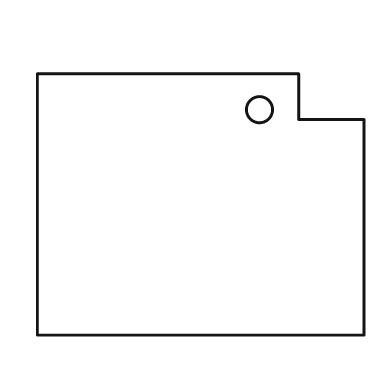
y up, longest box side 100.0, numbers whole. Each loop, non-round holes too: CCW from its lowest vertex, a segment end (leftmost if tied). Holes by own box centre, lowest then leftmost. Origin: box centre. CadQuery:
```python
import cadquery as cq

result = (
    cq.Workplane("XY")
    .moveTo(-50.0, -40.0)
    .lineTo(50.0, -40.0)
    .lineTo(50.0, 26.0)
    .lineTo(30.0, 26.0)
    .lineTo(30.0, 40.0)
    .lineTo(-50.0, 40.0)
    .close()
    .moveTo(18.0, 29.0)
    .circle(4.0)
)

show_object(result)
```